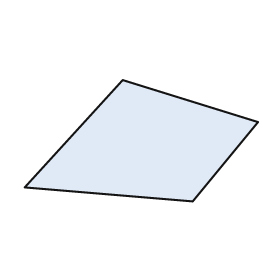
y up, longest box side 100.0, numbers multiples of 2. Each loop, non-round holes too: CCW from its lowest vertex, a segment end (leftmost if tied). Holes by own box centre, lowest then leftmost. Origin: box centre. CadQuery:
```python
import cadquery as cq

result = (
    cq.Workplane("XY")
    .moveTo(22.0, -26.0)
    .lineTo(50.0, 8.0)
    .lineTo(-8.0, 26.0)
    .lineTo(-50.0, -20.0)
    .close()
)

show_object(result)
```